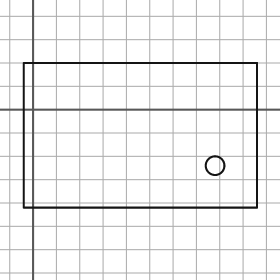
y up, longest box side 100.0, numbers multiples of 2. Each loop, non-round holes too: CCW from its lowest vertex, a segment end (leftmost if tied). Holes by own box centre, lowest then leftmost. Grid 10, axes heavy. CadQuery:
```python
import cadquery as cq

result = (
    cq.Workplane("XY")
    .moveTo(-4.0, -42.0)
    .lineTo(96.0, -42.0)
    .lineTo(96.0, 20.0)
    .lineTo(-4.0, 20.0)
    .close()
    .moveTo(78.0, -24.0)
    .circle(4.0)
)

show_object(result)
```